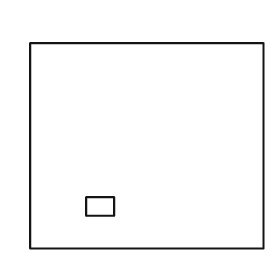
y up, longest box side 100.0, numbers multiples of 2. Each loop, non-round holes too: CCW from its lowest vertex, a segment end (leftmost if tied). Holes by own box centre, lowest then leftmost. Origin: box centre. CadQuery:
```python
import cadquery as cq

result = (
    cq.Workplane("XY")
    .moveTo(-50.0, -44.0)
    .lineTo(50.0, -44.0)
    .lineTo(50.0, 44.0)
    .lineTo(-50.0, 44.0)
    .close()
    .moveTo(-26.0, -30.0)
    .lineTo(-14.0, -30.0)
    .lineTo(-14.0, -22.0)
    .lineTo(-26.0, -22.0)
    .close()
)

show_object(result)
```